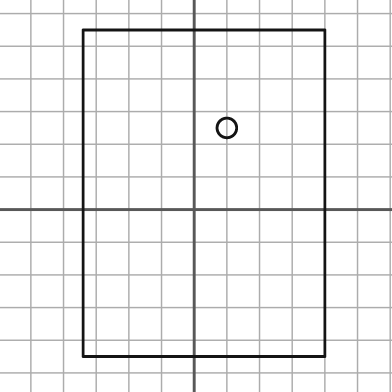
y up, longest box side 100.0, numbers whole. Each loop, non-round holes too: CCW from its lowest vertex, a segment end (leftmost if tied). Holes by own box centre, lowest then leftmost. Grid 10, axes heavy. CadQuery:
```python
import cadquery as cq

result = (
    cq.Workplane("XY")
    .moveTo(-34.0, -45.0)
    .lineTo(40.0, -45.0)
    .lineTo(40.0, 55.0)
    .lineTo(-34.0, 55.0)
    .close()
    .moveTo(10.0, 25.0)
    .circle(3.0)
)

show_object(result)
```